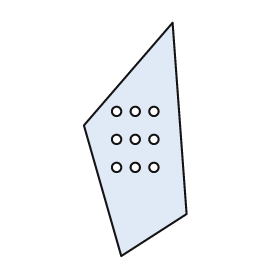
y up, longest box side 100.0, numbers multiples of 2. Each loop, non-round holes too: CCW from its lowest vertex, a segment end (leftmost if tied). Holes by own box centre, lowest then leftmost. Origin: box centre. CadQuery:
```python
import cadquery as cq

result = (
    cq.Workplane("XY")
    .moveTo(-6.0, -50.0)
    .lineTo(22.0, -32.0)
    .lineTo(16.0, 50.0)
    .lineTo(-22.0, 6.0)
    .close()
    .moveTo(-8.0, -12.0)
    .circle(2.0)
    .moveTo(0.0, -12.0)
    .circle(2.0)
    .moveTo(8.0, -12.0)
    .circle(2.0)
    .moveTo(-8.0, 0.0)
    .circle(2.0)
    .moveTo(0.0, 0.0)
    .circle(2.0)
    .moveTo(8.0, 0.0)
    .circle(2.0)
    .moveTo(-8.0, 12.0)
    .circle(2.0)
    .moveTo(0.0, 12.0)
    .circle(2.0)
    .moveTo(8.0, 12.0)
    .circle(2.0)
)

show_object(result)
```